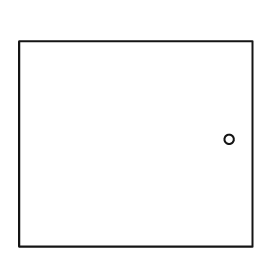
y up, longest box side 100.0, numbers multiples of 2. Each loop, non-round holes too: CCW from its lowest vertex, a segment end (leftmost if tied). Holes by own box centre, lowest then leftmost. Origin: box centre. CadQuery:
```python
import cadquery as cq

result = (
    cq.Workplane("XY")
    .moveTo(-50.0, -44.0)
    .lineTo(50.0, -44.0)
    .lineTo(50.0, 44.0)
    .lineTo(-50.0, 44.0)
    .close()
    .moveTo(40.0, 2.0)
    .circle(2.0)
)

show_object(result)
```